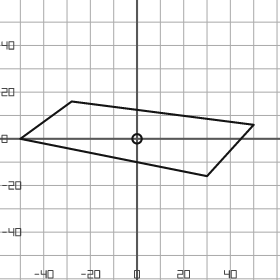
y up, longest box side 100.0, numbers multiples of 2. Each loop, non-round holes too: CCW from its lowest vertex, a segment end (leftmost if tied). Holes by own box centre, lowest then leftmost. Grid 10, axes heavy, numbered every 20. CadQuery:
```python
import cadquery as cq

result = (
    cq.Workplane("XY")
    .moveTo(30.0, -16.0)
    .lineTo(50.0, 6.0)
    .lineTo(-28.0, 16.0)
    .lineTo(-50.0, 0.0)
    .close()
    .moveTo(0.0, 0.0)
    .circle(2.0)
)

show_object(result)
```